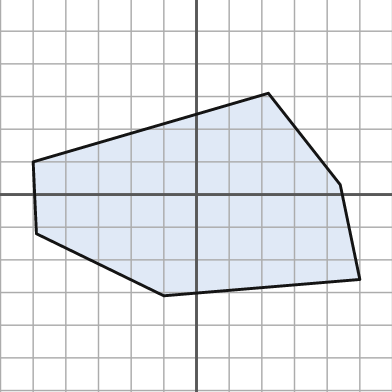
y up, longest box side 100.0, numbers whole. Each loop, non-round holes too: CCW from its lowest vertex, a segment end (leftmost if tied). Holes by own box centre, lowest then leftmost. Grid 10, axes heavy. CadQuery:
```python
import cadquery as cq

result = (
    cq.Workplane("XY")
    .moveTo(-10.0, -31.0)
    .lineTo(50.0, -26.0)
    .lineTo(44.0, 3.0)
    .lineTo(22.0, 31.0)
    .lineTo(-50.0, 10.0)
    .lineTo(-49.0, -12.0)
    .close()
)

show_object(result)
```